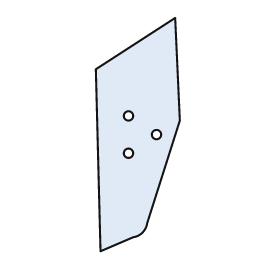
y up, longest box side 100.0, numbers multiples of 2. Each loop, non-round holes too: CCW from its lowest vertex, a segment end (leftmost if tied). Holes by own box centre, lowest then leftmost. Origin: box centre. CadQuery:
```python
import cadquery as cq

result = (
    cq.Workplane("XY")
    .moveTo(-16.0, -50.0)
    .lineTo(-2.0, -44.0)
    .threePointArc((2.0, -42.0), (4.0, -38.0))
    .lineTo(18.0, 6.0)
    .lineTo(16.0, 50.0)
    .lineTo(-18.0, 28.0)
    .close()
    .moveTo(-4.0, -8.0)
    .circle(2.0)
    .moveTo(8.0, 0.0)
    .circle(2.0)
    .moveTo(-4.0, 8.0)
    .circle(2.0)
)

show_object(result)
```